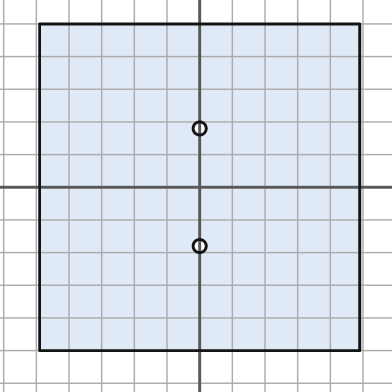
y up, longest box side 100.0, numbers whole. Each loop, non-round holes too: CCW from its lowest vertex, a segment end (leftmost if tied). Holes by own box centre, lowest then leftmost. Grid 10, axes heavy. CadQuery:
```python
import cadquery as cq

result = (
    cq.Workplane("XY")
    .moveTo(-49.0, -50.0)
    .lineTo(49.0, -50.0)
    .lineTo(49.0, 50.0)
    .lineTo(-49.0, 50.0)
    .close()
    .moveTo(0.0, -18.0)
    .circle(2.0)
    .moveTo(0.0, 18.0)
    .circle(2.0)
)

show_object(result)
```